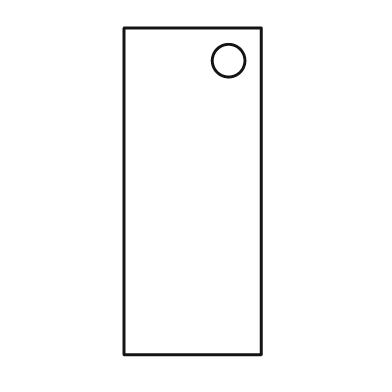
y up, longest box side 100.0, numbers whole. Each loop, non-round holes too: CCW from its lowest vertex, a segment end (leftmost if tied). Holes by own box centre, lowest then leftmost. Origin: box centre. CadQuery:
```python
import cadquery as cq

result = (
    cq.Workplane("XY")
    .moveTo(-21.0, -50.0)
    .lineTo(21.0, -50.0)
    .lineTo(21.0, 50.0)
    .lineTo(-21.0, 50.0)
    .close()
    .moveTo(11.0, 40.0)
    .circle(5.0)
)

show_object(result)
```